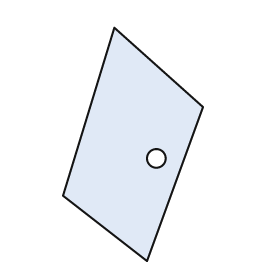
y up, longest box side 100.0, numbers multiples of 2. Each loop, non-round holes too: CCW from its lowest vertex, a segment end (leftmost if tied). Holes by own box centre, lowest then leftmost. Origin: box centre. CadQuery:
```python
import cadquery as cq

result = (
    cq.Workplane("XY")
    .moveTo(6.0, -50.0)
    .lineTo(30.0, 16.0)
    .lineTo(-8.0, 50.0)
    .lineTo(-30.0, -22.0)
    .close()
    .moveTo(10.0, -6.0)
    .circle(4.0)
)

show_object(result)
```